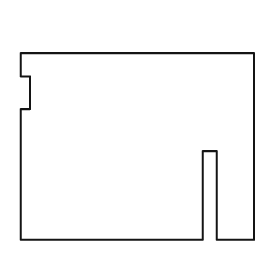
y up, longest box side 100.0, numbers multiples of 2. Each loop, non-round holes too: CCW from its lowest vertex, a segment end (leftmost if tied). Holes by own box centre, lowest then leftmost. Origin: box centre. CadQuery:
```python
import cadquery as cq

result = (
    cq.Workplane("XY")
    .moveTo(-50.0, -40.0)
    .lineTo(28.0, -40.0)
    .lineTo(28.0, -2.0)
    .lineTo(34.0, -2.0)
    .lineTo(34.0, -40.0)
    .lineTo(50.0, -40.0)
    .lineTo(50.0, 40.0)
    .lineTo(-50.0, 40.0)
    .lineTo(-50.0, 30.0)
    .lineTo(-46.0, 30.0)
    .lineTo(-46.0, 16.0)
    .lineTo(-50.0, 16.0)
    .close()
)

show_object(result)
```